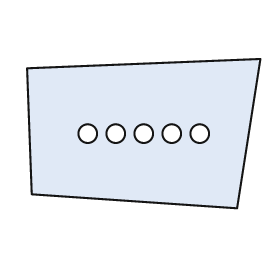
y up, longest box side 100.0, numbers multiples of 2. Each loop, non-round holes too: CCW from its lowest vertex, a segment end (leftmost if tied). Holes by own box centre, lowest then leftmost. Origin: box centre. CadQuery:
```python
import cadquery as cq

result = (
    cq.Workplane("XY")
    .moveTo(40.0, -32.0)
    .lineTo(50.0, 32.0)
    .lineTo(-50.0, 28.0)
    .lineTo(-48.0, -26.0)
    .close()
    .moveTo(-24.0, 0.0)
    .circle(4.0)
    .moveTo(-12.0, 0.0)
    .circle(4.0)
    .moveTo(0.0, 0.0)
    .circle(4.0)
    .moveTo(12.0, 0.0)
    .circle(4.0)
    .moveTo(24.0, 0.0)
    .circle(4.0)
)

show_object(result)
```